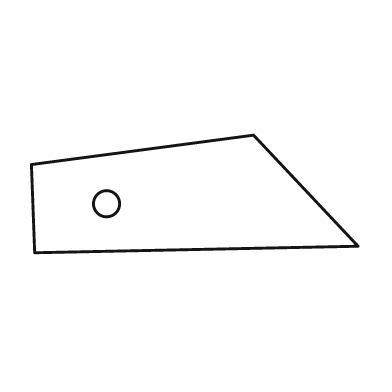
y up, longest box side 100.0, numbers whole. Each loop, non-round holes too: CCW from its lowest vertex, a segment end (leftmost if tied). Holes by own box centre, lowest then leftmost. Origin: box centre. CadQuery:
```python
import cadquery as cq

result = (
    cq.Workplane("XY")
    .moveTo(-49.0, -18.0)
    .lineTo(50.0, -16.0)
    .lineTo(18.0, 18.0)
    .lineTo(-50.0, 9.0)
    .close()
    .moveTo(-27.0, -3.0)
    .circle(4.0)
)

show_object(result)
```